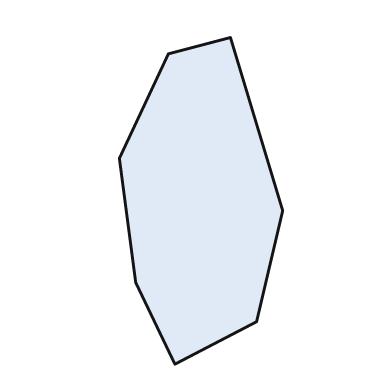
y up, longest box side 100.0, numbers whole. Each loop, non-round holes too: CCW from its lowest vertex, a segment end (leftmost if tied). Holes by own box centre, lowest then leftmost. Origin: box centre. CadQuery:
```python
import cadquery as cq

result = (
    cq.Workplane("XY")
    .moveTo(-8.0, -50.0)
    .lineTo(17.0, -37.0)
    .lineTo(25.0, -3.0)
    .lineTo(9.0, 50.0)
    .lineTo(-10.0, 45.0)
    .lineTo(-25.0, 13.0)
    .lineTo(-20.0, -25.0)
    .close()
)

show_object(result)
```